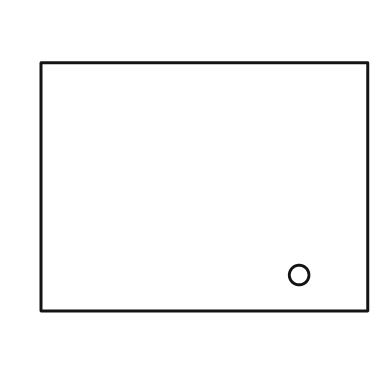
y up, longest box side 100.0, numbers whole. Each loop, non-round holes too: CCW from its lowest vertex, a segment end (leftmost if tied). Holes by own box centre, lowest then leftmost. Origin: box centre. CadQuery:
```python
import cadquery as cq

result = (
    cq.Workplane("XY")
    .moveTo(-50.0, -38.0)
    .lineTo(50.0, -38.0)
    .lineTo(50.0, 38.0)
    .lineTo(-50.0, 38.0)
    .close()
    .moveTo(29.0, -27.0)
    .circle(3.0)
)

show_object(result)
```